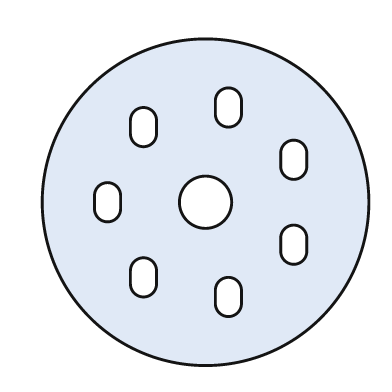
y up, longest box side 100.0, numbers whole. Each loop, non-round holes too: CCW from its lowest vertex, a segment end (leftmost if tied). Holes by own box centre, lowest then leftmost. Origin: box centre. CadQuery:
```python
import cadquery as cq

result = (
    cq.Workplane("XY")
    .moveTo(0.0, 0.0)
    .circle(50.0)
    .moveTo(3.0, -31.0)
    .threePointArc((7.0, -35.0), (11.0, -31.0))
    .lineTo(11.0, -27.0)
    .threePointArc((7.0, -23.0), (3.0, -27.0))
    .close()
    .moveTo(-23.0, -25.0)
    .threePointArc((-19.0, -29.0), (-15.0, -25.0))
    .lineTo(-15.0, -21.0)
    .threePointArc((-19.0, -17.0), (-23.0, -21.0))
    .close()
    .moveTo(23.0, -15.0)
    .threePointArc((27.0, -19.0), (31.0, -15.0))
    .lineTo(31.0, -11.0)
    .threePointArc((27.0, -7.0), (23.0, -11.0))
    .close()
    .moveTo(-34.0, -2.0)
    .threePointArc((-30.0, -6.0), (-26.0, -2.0))
    .lineTo(-26.0, 2.0)
    .threePointArc((-30.0, 6.0), (-34.0, 2.0))
    .close()
    .moveTo(0.0, 0.0)
    .circle(8.0)
    .moveTo(23.0, 11.0)
    .threePointArc((27.0, 7.0), (31.0, 11.0))
    .lineTo(31.0, 15.0)
    .threePointArc((27.0, 19.0), (23.0, 15.0))
    .close()
    .moveTo(-23.0, 21.0)
    .threePointArc((-19.0, 17.0), (-15.0, 21.0))
    .lineTo(-15.0, 25.0)
    .threePointArc((-19.0, 29.0), (-23.0, 25.0))
    .close()
    .moveTo(3.0, 27.0)
    .threePointArc((7.0, 23.0), (11.0, 27.0))
    .lineTo(11.0, 31.0)
    .threePointArc((7.0, 35.0), (3.0, 31.0))
    .close()
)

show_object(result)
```